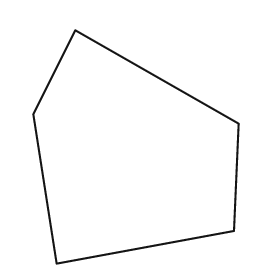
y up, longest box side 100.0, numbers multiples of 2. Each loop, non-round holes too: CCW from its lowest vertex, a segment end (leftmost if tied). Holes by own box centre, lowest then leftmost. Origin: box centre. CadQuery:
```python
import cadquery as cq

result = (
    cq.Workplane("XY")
    .moveTo(-34.0, -50.0)
    .lineTo(42.0, -36.0)
    .lineTo(44.0, 10.0)
    .lineTo(-26.0, 50.0)
    .lineTo(-44.0, 14.0)
    .close()
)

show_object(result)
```